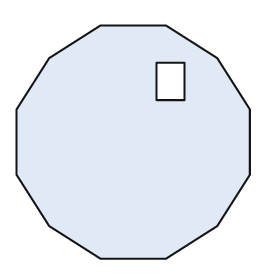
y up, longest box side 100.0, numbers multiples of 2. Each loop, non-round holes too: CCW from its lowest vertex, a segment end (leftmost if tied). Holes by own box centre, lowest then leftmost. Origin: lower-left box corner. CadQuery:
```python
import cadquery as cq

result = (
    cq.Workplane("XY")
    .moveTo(36.0, 0.0)
    .lineTo(64.0, 0.0)
    .lineTo(86.0, 14.0)
    .lineTo(100.0, 36.0)
    .lineTo(100.0, 64.0)
    .lineTo(86.0, 86.0)
    .lineTo(64.0, 100.0)
    .lineTo(36.0, 100.0)
    .lineTo(14.0, 86.0)
    .lineTo(0.0, 64.0)
    .lineTo(0.0, 36.0)
    .lineTo(14.0, 14.0)
    .close()
    .moveTo(60.0, 68.0)
    .lineTo(72.0, 68.0)
    .lineTo(72.0, 84.0)
    .lineTo(60.0, 84.0)
    .close()
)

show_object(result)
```